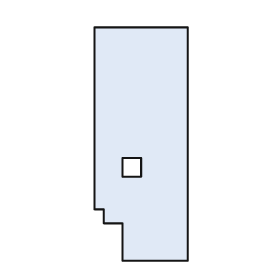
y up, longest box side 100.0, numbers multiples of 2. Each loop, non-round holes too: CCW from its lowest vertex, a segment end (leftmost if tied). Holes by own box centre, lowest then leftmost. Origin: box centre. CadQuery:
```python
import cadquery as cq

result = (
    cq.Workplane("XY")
    .moveTo(-8.0, -50.0)
    .lineTo(20.0, -50.0)
    .lineTo(20.0, 50.0)
    .lineTo(-20.0, 50.0)
    .lineTo(-20.0, -28.0)
    .lineTo(-16.0, -28.0)
    .lineTo(-16.0, -34.0)
    .lineTo(-8.0, -34.0)
    .close()
    .moveTo(-8.0, -14.0)
    .lineTo(0.0, -14.0)
    .lineTo(0.0, -6.0)
    .lineTo(-8.0, -6.0)
    .close()
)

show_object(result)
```